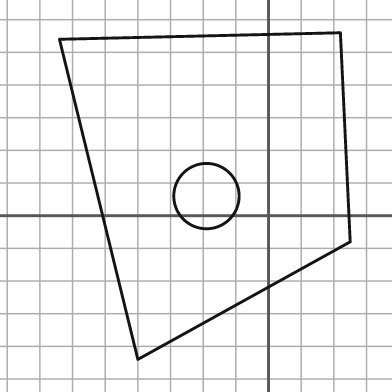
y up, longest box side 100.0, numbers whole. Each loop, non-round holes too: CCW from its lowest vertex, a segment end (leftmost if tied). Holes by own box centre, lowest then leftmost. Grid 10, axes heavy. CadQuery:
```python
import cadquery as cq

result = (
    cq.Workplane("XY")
    .moveTo(-40.0, -44.0)
    .lineTo(25.0, -8.0)
    .lineTo(22.0, 56.0)
    .lineTo(-64.0, 54.0)
    .close()
    .moveTo(-19.0, 6.0)
    .circle(10.0)
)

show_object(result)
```